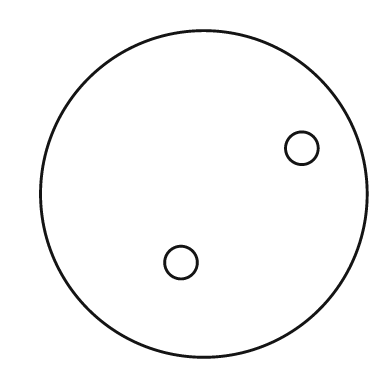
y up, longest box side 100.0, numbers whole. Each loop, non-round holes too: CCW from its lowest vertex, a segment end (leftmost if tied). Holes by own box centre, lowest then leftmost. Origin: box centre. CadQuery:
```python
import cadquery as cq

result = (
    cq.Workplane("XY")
    .moveTo(0.0, 0.0)
    .circle(50.0)
    .moveTo(-7.0, -21.0)
    .circle(5.0)
    .moveTo(30.0, 14.0)
    .circle(5.0)
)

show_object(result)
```